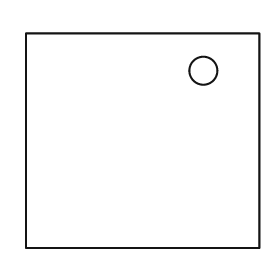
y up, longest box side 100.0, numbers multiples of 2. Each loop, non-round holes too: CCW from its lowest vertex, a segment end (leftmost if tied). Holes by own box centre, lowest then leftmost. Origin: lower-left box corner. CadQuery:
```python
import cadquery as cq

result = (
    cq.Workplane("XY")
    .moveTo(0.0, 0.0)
    .lineTo(100.0, 0.0)
    .lineTo(100.0, 92.0)
    .lineTo(0.0, 92.0)
    .close()
    .moveTo(76.0, 76.0)
    .circle(6.0)
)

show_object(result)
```